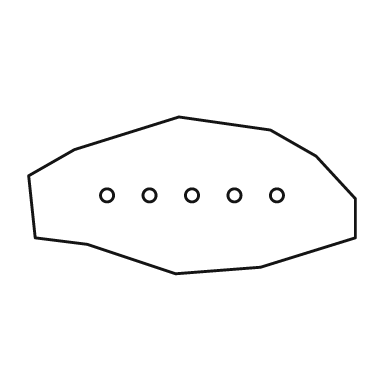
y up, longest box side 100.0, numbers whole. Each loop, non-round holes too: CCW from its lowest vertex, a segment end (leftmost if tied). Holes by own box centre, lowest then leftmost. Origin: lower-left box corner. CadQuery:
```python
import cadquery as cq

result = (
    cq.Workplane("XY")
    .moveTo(45.0, 0.0)
    .lineTo(71.0, 2.0)
    .lineTo(100.0, 11.0)
    .lineTo(100.0, 23.0)
    .lineTo(88.0, 36.0)
    .lineTo(74.0, 44.0)
    .lineTo(46.0, 48.0)
    .lineTo(14.0, 38.0)
    .lineTo(0.0, 30.0)
    .lineTo(2.0, 11.0)
    .lineTo(18.0, 9.0)
    .close()
    .moveTo(24.0, 24.0)
    .circle(2.0)
    .moveTo(37.0, 24.0)
    .circle(2.0)
    .moveTo(50.0, 24.0)
    .circle(2.0)
    .moveTo(63.0, 24.0)
    .circle(2.0)
    .moveTo(76.0, 24.0)
    .circle(2.0)
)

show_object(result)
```